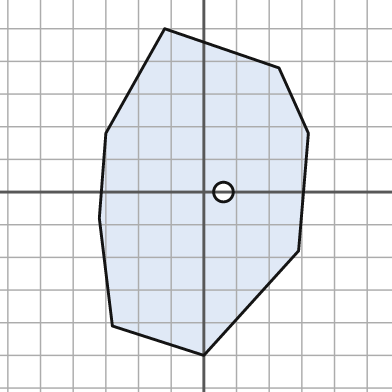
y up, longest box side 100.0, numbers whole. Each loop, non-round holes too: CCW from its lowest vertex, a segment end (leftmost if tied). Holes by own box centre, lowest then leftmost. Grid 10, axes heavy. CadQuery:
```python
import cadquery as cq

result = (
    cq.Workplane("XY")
    .moveTo(0.0, -50.0)
    .lineTo(29.0, -18.0)
    .lineTo(32.0, 18.0)
    .lineTo(23.0, 38.0)
    .lineTo(-12.0, 50.0)
    .lineTo(-30.0, 18.0)
    .lineTo(-32.0, -8.0)
    .lineTo(-28.0, -41.0)
    .close()
    .moveTo(6.0, 0.0)
    .circle(3.0)
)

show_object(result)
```